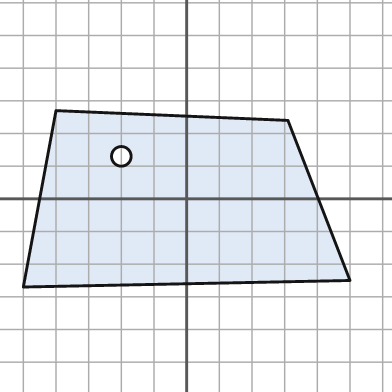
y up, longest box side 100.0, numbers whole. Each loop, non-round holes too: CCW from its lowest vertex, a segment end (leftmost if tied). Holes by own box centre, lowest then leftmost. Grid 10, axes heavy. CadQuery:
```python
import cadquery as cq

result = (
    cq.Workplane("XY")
    .moveTo(-50.0, -27.0)
    .lineTo(50.0, -25.0)
    .lineTo(31.0, 24.0)
    .lineTo(-40.0, 27.0)
    .close()
    .moveTo(-20.0, 13.0)
    .circle(3.0)
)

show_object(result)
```